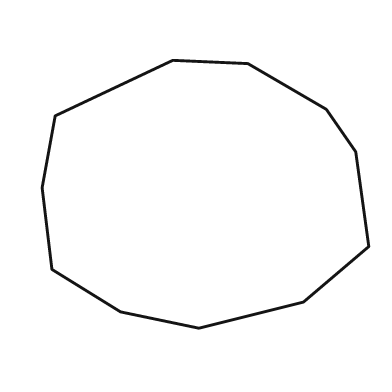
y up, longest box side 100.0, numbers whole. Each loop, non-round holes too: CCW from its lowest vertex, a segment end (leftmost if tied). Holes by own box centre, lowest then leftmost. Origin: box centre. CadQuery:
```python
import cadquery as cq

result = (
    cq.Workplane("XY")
    .moveTo(-2.0, -41.0)
    .lineTo(30.0, -33.0)
    .lineTo(50.0, -16.0)
    .lineTo(46.0, 13.0)
    .lineTo(37.0, 26.0)
    .lineTo(13.0, 40.0)
    .lineTo(-10.0, 41.0)
    .lineTo(-46.0, 24.0)
    .lineTo(-50.0, 2.0)
    .lineTo(-47.0, -23.0)
    .lineTo(-26.0, -36.0)
    .close()
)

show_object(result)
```